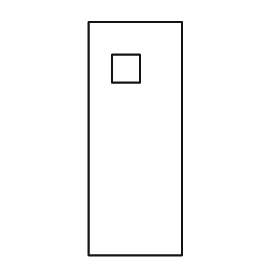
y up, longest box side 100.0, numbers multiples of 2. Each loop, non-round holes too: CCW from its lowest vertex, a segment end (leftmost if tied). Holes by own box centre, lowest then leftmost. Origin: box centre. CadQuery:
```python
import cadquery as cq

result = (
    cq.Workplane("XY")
    .moveTo(-20.0, -50.0)
    .lineTo(20.0, -50.0)
    .lineTo(20.0, 50.0)
    .lineTo(-20.0, 50.0)
    .close()
    .moveTo(-10.0, 24.0)
    .lineTo(2.0, 24.0)
    .lineTo(2.0, 36.0)
    .lineTo(-10.0, 36.0)
    .close()
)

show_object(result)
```